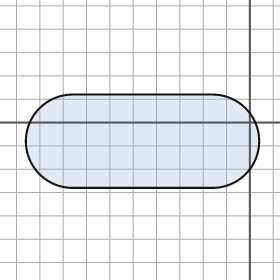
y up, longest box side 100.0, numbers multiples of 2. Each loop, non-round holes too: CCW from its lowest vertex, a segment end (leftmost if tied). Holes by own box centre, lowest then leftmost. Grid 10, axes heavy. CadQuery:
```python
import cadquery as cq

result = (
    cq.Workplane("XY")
    .moveTo(-76.0, -28.0)
    .lineTo(-16.0, -28.0)
    .threePointArc((4.0, -8.0), (-16.0, 12.0))
    .lineTo(-76.0, 12.0)
    .threePointArc((-96.0, -8.0), (-76.0, -28.0))
    .close()
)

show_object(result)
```